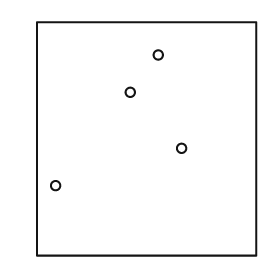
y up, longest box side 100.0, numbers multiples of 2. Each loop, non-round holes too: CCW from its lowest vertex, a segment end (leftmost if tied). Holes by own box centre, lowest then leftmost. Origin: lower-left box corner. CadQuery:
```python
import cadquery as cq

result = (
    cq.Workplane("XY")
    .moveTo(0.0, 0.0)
    .lineTo(94.0, 0.0)
    .lineTo(94.0, 100.0)
    .lineTo(0.0, 100.0)
    .close()
    .moveTo(8.0, 30.0)
    .circle(2.0)
    .moveTo(62.0, 46.0)
    .circle(2.0)
    .moveTo(40.0, 70.0)
    .circle(2.0)
    .moveTo(52.0, 86.0)
    .circle(2.0)
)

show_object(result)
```